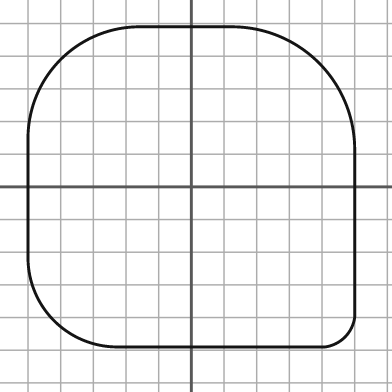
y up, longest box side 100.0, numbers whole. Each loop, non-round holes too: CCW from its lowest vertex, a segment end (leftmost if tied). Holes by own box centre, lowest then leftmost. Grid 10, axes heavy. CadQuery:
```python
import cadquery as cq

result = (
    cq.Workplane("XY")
    .moveTo(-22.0, -49.0)
    .lineTo(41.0, -49.0)
    .threePointArc((47.0, -46.0), (50.0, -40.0))
    .lineTo(50.0, 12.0)
    .threePointArc((39.0, 38.0), (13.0, 49.0))
    .lineTo(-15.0, 49.0)
    .threePointArc((-40.0, 39.0), (-50.0, 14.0))
    .lineTo(-50.0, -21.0)
    .threePointArc((-42.0, -41.0), (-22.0, -49.0))
    .close()
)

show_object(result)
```